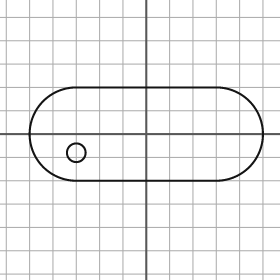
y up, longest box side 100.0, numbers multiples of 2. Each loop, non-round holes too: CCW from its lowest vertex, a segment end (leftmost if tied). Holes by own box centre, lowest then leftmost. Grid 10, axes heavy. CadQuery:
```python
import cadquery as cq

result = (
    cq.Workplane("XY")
    .moveTo(-30.0, -20.0)
    .lineTo(30.0, -20.0)
    .threePointArc((50.0, 0.0), (30.0, 20.0))
    .lineTo(-30.0, 20.0)
    .threePointArc((-50.0, 0.0), (-30.0, -20.0))
    .close()
    .moveTo(-30.0, -8.0)
    .circle(4.0)
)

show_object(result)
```